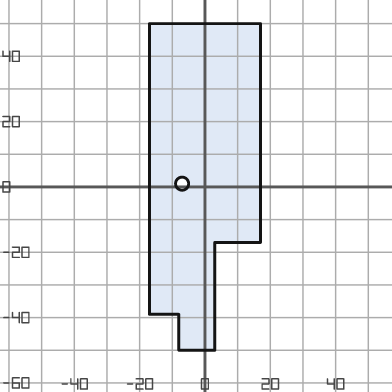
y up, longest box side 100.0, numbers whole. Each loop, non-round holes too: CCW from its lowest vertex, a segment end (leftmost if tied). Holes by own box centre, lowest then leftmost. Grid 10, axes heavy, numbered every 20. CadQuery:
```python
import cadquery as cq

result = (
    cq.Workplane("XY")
    .moveTo(-8.0, -50.0)
    .lineTo(3.0, -50.0)
    .lineTo(3.0, -17.0)
    .lineTo(17.0, -17.0)
    .lineTo(17.0, 50.0)
    .lineTo(-17.0, 50.0)
    .lineTo(-17.0, -39.0)
    .lineTo(-8.0, -39.0)
    .close()
    .moveTo(-7.0, 1.0)
    .circle(2.0)
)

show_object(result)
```